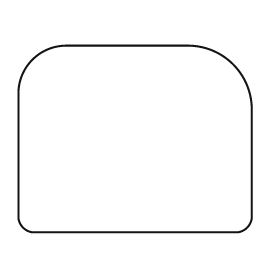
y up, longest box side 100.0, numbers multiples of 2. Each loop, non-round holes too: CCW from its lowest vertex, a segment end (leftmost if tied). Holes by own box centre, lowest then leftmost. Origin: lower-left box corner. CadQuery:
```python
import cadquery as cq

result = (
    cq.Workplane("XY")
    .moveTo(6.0, 0.0)
    .lineTo(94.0, 0.0)
    .threePointArc((98.0, 2.0), (100.0, 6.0))
    .lineTo(100.0, 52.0)
    .threePointArc((92.0, 72.0), (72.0, 80.0))
    .lineTo(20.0, 80.0)
    .threePointArc((6.0, 74.0), (0.0, 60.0))
    .lineTo(0.0, 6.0)
    .threePointArc((2.0, 2.0), (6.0, 0.0))
    .close()
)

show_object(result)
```